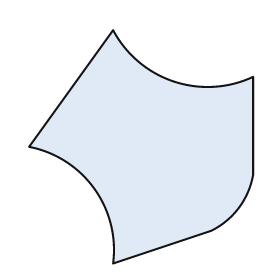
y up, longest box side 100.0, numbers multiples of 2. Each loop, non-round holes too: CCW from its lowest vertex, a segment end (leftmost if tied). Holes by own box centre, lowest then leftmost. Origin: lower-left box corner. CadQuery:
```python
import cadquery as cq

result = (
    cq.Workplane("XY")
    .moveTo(36.0, 0.0)
    .lineTo(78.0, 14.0)
    .threePointArc((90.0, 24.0), (96.0, 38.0))
    .lineTo(96.0, 80.0)
    .threePointArc((62.0, 78.0), (36.0, 100.0))
    .lineTo(0.0, 50.0)
    .threePointArc((28.0, 32.0), (36.0, 0.0))
    .close()
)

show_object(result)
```